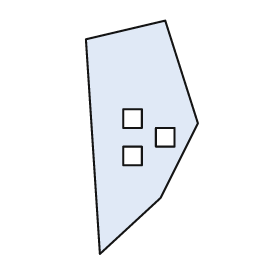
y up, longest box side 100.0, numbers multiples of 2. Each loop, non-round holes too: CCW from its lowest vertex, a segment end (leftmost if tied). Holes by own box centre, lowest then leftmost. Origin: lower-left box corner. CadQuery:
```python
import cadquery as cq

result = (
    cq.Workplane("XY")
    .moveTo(6.0, 0.0)
    .lineTo(32.0, 24.0)
    .lineTo(48.0, 56.0)
    .lineTo(34.0, 100.0)
    .lineTo(0.0, 92.0)
    .close()
    .moveTo(16.0, 38.0)
    .lineTo(24.0, 38.0)
    .lineTo(24.0, 46.0)
    .lineTo(16.0, 46.0)
    .close()
    .moveTo(30.0, 46.0)
    .lineTo(38.0, 46.0)
    .lineTo(38.0, 54.0)
    .lineTo(30.0, 54.0)
    .close()
    .moveTo(16.0, 54.0)
    .lineTo(24.0, 54.0)
    .lineTo(24.0, 62.0)
    .lineTo(16.0, 62.0)
    .close()
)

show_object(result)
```